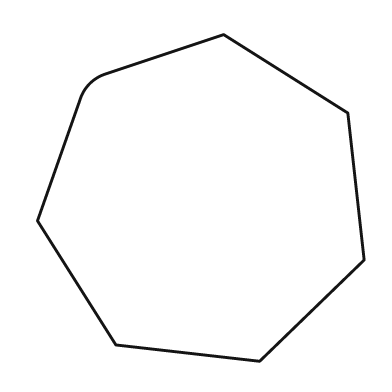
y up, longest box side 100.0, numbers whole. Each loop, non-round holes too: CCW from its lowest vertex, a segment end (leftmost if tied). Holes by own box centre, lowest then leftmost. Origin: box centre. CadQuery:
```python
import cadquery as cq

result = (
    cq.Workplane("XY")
    .moveTo(18.0, -50.0)
    .lineTo(50.0, -19.0)
    .lineTo(45.0, 26.0)
    .lineTo(7.0, 50.0)
    .lineTo(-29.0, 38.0)
    .threePointArc((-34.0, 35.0), (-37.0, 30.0))
    .lineTo(-50.0, -7.0)
    .lineTo(-26.0, -45.0)
    .close()
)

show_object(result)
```